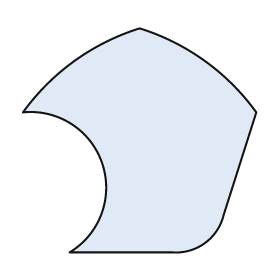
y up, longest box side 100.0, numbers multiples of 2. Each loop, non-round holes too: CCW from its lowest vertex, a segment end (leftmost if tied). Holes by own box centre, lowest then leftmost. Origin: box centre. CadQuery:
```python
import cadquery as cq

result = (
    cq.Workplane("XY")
    .moveTo(-30.0, -48.0)
    .lineTo(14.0, -48.0)
    .threePointArc((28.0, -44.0), (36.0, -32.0))
    .lineTo(50.0, 12.0)
    .threePointArc((28.0, 34.0), (0.0, 48.0))
    .threePointArc((-28.0, 34.0), (-50.0, 12.0))
    .threePointArc((-16.0, -10.0), (-30.0, -48.0))
    .close()
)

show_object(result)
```